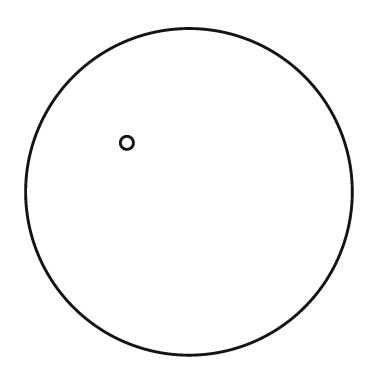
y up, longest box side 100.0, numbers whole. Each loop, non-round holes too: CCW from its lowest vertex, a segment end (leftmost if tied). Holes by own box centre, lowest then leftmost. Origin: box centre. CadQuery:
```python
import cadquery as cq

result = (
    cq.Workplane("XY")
    .moveTo(0.0, 0.0)
    .circle(50.0)
    .moveTo(-19.0, 15.0)
    .circle(2.0)
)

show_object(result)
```